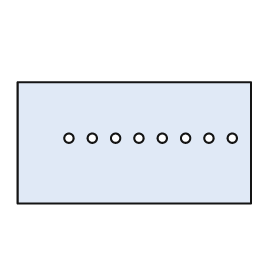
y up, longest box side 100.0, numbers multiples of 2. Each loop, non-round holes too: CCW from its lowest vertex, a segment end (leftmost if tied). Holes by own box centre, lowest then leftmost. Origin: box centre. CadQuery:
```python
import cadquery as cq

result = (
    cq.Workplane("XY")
    .moveTo(-50.0, -26.0)
    .lineTo(50.0, -26.0)
    .lineTo(50.0, 26.0)
    .lineTo(-50.0, 26.0)
    .close()
    .moveTo(-28.0, 2.0)
    .circle(2.0)
    .moveTo(-18.0, 2.0)
    .circle(2.0)
    .moveTo(-8.0, 2.0)
    .circle(2.0)
    .moveTo(2.0, 2.0)
    .circle(2.0)
    .moveTo(12.0, 2.0)
    .circle(2.0)
    .moveTo(22.0, 2.0)
    .circle(2.0)
    .moveTo(32.0, 2.0)
    .circle(2.0)
    .moveTo(42.0, 2.0)
    .circle(2.0)
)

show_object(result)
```